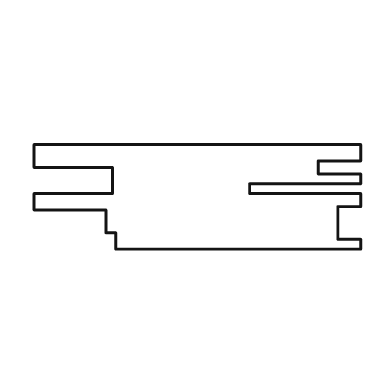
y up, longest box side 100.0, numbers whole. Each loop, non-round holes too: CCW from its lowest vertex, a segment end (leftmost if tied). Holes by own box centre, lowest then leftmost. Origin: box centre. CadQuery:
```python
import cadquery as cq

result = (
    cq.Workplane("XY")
    .moveTo(-25.0, -16.0)
    .lineTo(50.0, -16.0)
    .lineTo(50.0, -13.0)
    .lineTo(43.0, -13.0)
    .lineTo(43.0, -3.0)
    .lineTo(50.0, -3.0)
    .lineTo(50.0, 1.0)
    .lineTo(16.0, 1.0)
    .lineTo(16.0, 4.0)
    .lineTo(50.0, 4.0)
    .lineTo(50.0, 7.0)
    .lineTo(37.0, 7.0)
    .lineTo(37.0, 11.0)
    .lineTo(50.0, 11.0)
    .lineTo(50.0, 16.0)
    .lineTo(-50.0, 16.0)
    .lineTo(-50.0, 9.0)
    .lineTo(-26.0, 9.0)
    .lineTo(-26.0, 1.0)
    .lineTo(-50.0, 1.0)
    .lineTo(-50.0, -4.0)
    .lineTo(-28.0, -4.0)
    .lineTo(-28.0, -11.0)
    .lineTo(-25.0, -11.0)
    .close()
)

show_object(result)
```